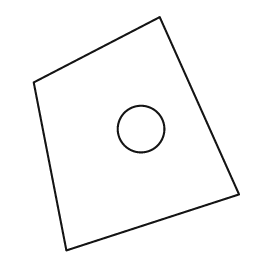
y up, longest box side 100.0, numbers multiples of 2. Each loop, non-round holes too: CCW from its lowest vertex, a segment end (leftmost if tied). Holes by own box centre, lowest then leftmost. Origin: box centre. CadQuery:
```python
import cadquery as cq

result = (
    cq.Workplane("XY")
    .moveTo(-30.0, -50.0)
    .lineTo(44.0, -26.0)
    .lineTo(10.0, 50.0)
    .lineTo(-44.0, 22.0)
    .close()
    .moveTo(2.0, 2.0)
    .circle(10.0)
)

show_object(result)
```